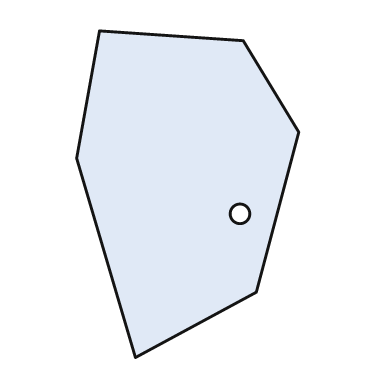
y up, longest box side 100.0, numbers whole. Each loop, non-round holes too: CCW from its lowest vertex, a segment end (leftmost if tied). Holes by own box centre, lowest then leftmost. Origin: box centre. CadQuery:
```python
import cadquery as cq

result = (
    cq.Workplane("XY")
    .moveTo(-16.0, -50.0)
    .lineTo(21.0, -30.0)
    .lineTo(34.0, 19.0)
    .lineTo(17.0, 47.0)
    .lineTo(-27.0, 50.0)
    .lineTo(-34.0, 11.0)
    .close()
    .moveTo(16.0, -6.0)
    .circle(3.0)
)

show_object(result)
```